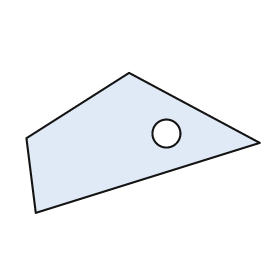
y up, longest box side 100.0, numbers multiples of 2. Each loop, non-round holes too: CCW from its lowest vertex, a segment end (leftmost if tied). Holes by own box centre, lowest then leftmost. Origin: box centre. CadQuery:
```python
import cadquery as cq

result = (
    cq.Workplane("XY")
    .moveTo(-46.0, -30.0)
    .lineTo(50.0, 0.0)
    .lineTo(-6.0, 30.0)
    .lineTo(-50.0, 2.0)
    .close()
    .moveTo(10.0, 4.0)
    .circle(6.0)
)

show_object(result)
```